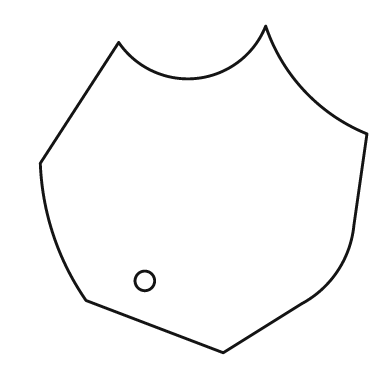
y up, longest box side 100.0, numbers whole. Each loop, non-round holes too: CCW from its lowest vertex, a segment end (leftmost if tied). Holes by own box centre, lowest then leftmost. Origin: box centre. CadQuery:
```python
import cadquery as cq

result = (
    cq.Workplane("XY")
    .moveTo(6.0, -50.0)
    .lineTo(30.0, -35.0)
    .threePointArc((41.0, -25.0), (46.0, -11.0))
    .lineTo(50.0, 17.0)
    .threePointArc((31.0, 30.0), (19.0, 50.0))
    .threePointArc((-2.0, 34.0), (-26.0, 45.0))
    .lineTo(-50.0, 8.0)
    .threePointArc((-46.0, -14.0), (-36.0, -34.0))
    .close()
    .moveTo(-18.0, -28.0)
    .circle(3.0)
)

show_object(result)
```